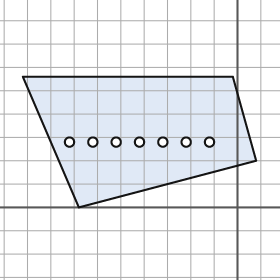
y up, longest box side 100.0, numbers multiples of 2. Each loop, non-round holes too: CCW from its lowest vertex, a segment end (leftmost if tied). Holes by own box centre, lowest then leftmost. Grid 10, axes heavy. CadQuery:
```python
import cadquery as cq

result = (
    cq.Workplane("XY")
    .moveTo(-68.0, 0.0)
    .lineTo(8.0, 20.0)
    .lineTo(-2.0, 56.0)
    .lineTo(-92.0, 56.0)
    .close()
    .moveTo(-72.0, 28.0)
    .circle(2.0)
    .moveTo(-62.0, 28.0)
    .circle(2.0)
    .moveTo(-52.0, 28.0)
    .circle(2.0)
    .moveTo(-42.0, 28.0)
    .circle(2.0)
    .moveTo(-32.0, 28.0)
    .circle(2.0)
    .moveTo(-22.0, 28.0)
    .circle(2.0)
    .moveTo(-12.0, 28.0)
    .circle(2.0)
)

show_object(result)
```